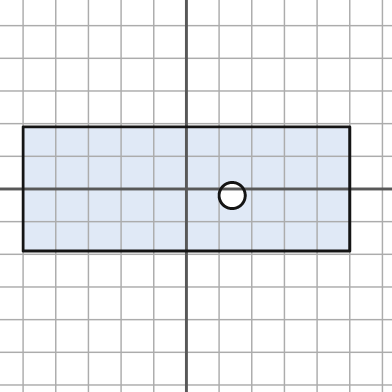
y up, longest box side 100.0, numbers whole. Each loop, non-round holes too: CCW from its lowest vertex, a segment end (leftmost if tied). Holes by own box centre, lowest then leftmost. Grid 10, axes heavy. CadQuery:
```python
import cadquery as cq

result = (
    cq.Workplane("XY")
    .moveTo(-50.0, -19.0)
    .lineTo(50.0, -19.0)
    .lineTo(50.0, 19.0)
    .lineTo(-50.0, 19.0)
    .close()
    .moveTo(14.0, -2.0)
    .circle(4.0)
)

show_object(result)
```